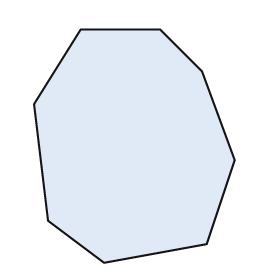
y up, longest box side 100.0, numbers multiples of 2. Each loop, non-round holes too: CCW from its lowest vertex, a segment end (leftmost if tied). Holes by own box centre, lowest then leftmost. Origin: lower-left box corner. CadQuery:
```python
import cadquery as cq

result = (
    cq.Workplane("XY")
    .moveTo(30.0, 0.0)
    .lineTo(74.0, 8.0)
    .lineTo(86.0, 44.0)
    .lineTo(72.0, 82.0)
    .lineTo(54.0, 100.0)
    .lineTo(20.0, 100.0)
    .lineTo(0.0, 68.0)
    .lineTo(6.0, 18.0)
    .close()
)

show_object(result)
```